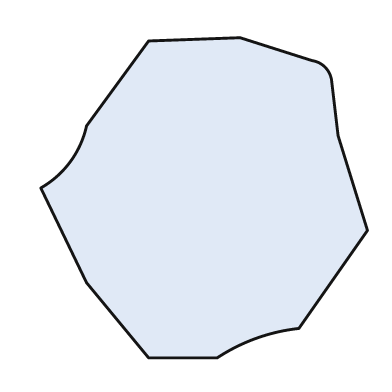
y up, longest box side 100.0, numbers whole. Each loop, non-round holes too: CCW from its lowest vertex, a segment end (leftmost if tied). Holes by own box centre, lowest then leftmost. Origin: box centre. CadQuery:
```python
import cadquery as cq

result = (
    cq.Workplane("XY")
    .moveTo(-17.0, -49.0)
    .lineTo(4.0, -49.0)
    .threePointArc((16.0, -43.0), (29.0, -40.0))
    .lineTo(50.0, -10.0)
    .lineTo(41.0, 19.0)
    .lineTo(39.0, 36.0)
    .threePointArc((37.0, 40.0), (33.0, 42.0))
    .lineTo(11.0, 49.0)
    .lineTo(-17.0, 48.0)
    .lineTo(-36.0, 22.0)
    .threePointArc((-41.0, 11.0), (-50.0, 3.0))
    .lineTo(-36.0, -26.0)
    .close()
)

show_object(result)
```